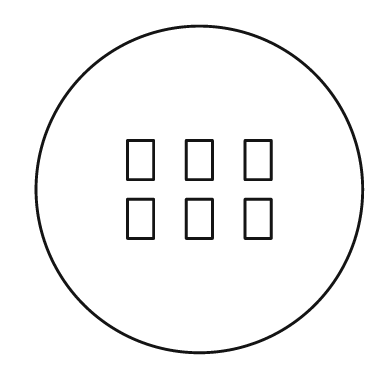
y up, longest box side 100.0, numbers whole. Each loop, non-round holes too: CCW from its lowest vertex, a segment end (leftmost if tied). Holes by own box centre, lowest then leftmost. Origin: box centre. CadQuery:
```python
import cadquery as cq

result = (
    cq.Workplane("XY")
    .moveTo(0.0, 0.0)
    .circle(50.0)
    .moveTo(-22.0, -15.0)
    .lineTo(-14.0, -15.0)
    .lineTo(-14.0, -3.0)
    .lineTo(-22.0, -3.0)
    .close()
    .moveTo(-4.0, -15.0)
    .lineTo(4.0, -15.0)
    .lineTo(4.0, -3.0)
    .lineTo(-4.0, -3.0)
    .close()
    .moveTo(14.0, -15.0)
    .lineTo(22.0, -15.0)
    .lineTo(22.0, -3.0)
    .lineTo(14.0, -3.0)
    .close()
    .moveTo(-22.0, 3.0)
    .lineTo(-14.0, 3.0)
    .lineTo(-14.0, 15.0)
    .lineTo(-22.0, 15.0)
    .close()
    .moveTo(-4.0, 3.0)
    .lineTo(4.0, 3.0)
    .lineTo(4.0, 15.0)
    .lineTo(-4.0, 15.0)
    .close()
    .moveTo(14.0, 3.0)
    .lineTo(22.0, 3.0)
    .lineTo(22.0, 15.0)
    .lineTo(14.0, 15.0)
    .close()
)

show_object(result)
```